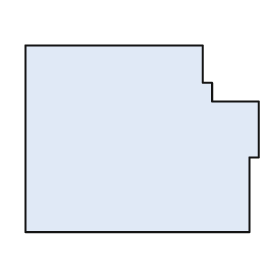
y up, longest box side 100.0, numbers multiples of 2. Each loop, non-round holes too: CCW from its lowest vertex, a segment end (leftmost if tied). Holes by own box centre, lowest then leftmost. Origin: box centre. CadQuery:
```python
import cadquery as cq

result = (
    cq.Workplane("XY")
    .moveTo(-50.0, -40.0)
    .lineTo(46.0, -40.0)
    .lineTo(46.0, -8.0)
    .lineTo(50.0, -8.0)
    .lineTo(50.0, 16.0)
    .lineTo(30.0, 16.0)
    .lineTo(30.0, 24.0)
    .lineTo(26.0, 24.0)
    .lineTo(26.0, 40.0)
    .lineTo(-50.0, 40.0)
    .close()
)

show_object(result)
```